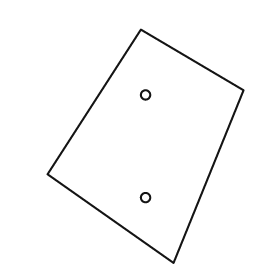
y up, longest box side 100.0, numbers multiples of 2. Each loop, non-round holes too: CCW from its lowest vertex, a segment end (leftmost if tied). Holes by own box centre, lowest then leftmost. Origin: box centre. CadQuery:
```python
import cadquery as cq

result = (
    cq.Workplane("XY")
    .moveTo(12.0, -50.0)
    .lineTo(42.0, 24.0)
    .lineTo(-2.0, 50.0)
    .lineTo(-42.0, -12.0)
    .close()
    .moveTo(0.0, -22.0)
    .circle(2.0)
    .moveTo(0.0, 22.0)
    .circle(2.0)
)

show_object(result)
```